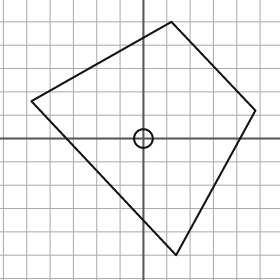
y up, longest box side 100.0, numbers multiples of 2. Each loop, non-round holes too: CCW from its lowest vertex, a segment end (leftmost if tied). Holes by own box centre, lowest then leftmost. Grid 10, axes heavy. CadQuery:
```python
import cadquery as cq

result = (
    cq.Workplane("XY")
    .moveTo(14.0, -50.0)
    .lineTo(48.0, 12.0)
    .lineTo(12.0, 50.0)
    .lineTo(-48.0, 16.0)
    .close()
    .moveTo(0.0, 0.0)
    .circle(4.0)
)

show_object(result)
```